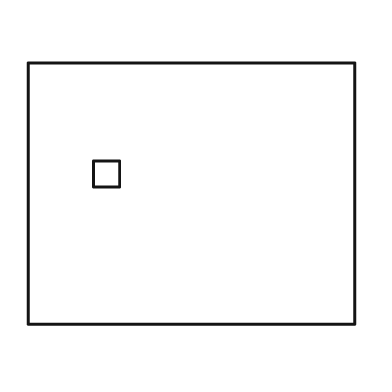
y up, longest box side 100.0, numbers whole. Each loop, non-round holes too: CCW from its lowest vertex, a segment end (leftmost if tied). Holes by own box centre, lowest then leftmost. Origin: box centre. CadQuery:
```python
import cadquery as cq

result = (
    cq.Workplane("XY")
    .moveTo(-50.0, -40.0)
    .lineTo(50.0, -40.0)
    .lineTo(50.0, 40.0)
    .lineTo(-50.0, 40.0)
    .close()
    .moveTo(-30.0, 2.0)
    .lineTo(-22.0, 2.0)
    .lineTo(-22.0, 10.0)
    .lineTo(-30.0, 10.0)
    .close()
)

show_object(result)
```